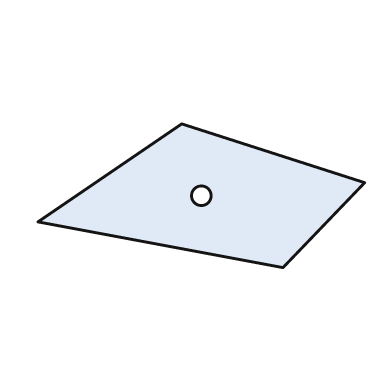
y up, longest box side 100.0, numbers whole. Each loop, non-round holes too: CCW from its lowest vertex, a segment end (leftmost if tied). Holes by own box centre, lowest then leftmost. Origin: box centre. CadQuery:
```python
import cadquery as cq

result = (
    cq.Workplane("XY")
    .moveTo(25.0, -22.0)
    .lineTo(50.0, 4.0)
    .lineTo(-6.0, 22.0)
    .lineTo(-50.0, -8.0)
    .close()
    .moveTo(0.0, 0.0)
    .circle(3.0)
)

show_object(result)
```